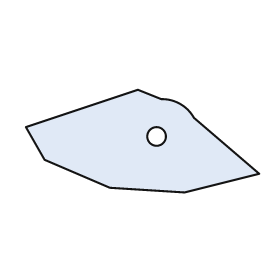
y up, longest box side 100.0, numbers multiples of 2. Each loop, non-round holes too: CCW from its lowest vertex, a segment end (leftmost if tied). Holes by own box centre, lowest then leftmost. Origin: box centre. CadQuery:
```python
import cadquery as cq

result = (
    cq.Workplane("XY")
    .moveTo(18.0, -22.0)
    .lineTo(50.0, -14.0)
    .lineTo(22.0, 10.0)
    .threePointArc((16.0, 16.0), (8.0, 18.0))
    .lineTo(-2.0, 22.0)
    .lineTo(-50.0, 6.0)
    .lineTo(-42.0, -8.0)
    .lineTo(-14.0, -20.0)
    .close()
    .moveTo(6.0, 2.0)
    .circle(4.0)
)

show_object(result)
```